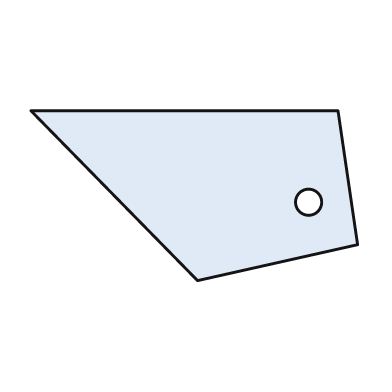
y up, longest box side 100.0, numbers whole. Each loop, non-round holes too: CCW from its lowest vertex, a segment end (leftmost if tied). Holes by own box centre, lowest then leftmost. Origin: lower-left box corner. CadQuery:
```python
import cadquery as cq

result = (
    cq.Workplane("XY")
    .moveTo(51.0, 0.0)
    .lineTo(100.0, 11.0)
    .lineTo(94.0, 52.0)
    .lineTo(0.0, 52.0)
    .close()
    .moveTo(85.0, 24.0)
    .circle(4.0)
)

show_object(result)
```